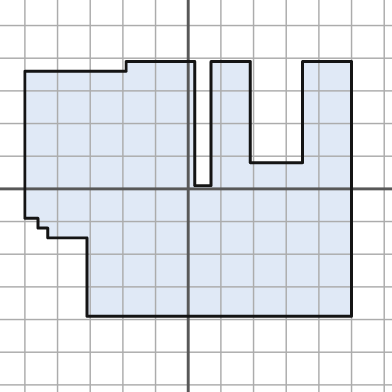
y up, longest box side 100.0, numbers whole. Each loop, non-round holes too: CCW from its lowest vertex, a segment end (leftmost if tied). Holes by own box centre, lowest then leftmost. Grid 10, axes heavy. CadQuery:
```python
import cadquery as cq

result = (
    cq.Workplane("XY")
    .moveTo(-31.0, -39.0)
    .lineTo(50.0, -39.0)
    .lineTo(50.0, 39.0)
    .lineTo(35.0, 39.0)
    .lineTo(35.0, 8.0)
    .lineTo(19.0, 8.0)
    .lineTo(19.0, 39.0)
    .lineTo(7.0, 39.0)
    .lineTo(7.0, 1.0)
    .lineTo(2.0, 1.0)
    .lineTo(2.0, 39.0)
    .lineTo(-19.0, 39.0)
    .lineTo(-19.0, 36.0)
    .lineTo(-50.0, 36.0)
    .lineTo(-50.0, -9.0)
    .lineTo(-46.0, -9.0)
    .lineTo(-46.0, -12.0)
    .lineTo(-43.0, -12.0)
    .lineTo(-43.0, -15.0)
    .lineTo(-31.0, -15.0)
    .close()
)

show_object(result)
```